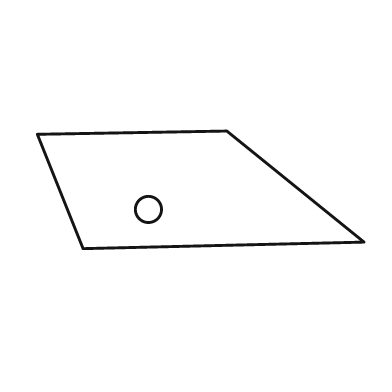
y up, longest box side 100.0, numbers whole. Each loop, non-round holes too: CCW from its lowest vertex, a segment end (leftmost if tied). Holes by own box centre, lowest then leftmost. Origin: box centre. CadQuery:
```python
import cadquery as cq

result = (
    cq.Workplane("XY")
    .moveTo(-36.0, -18.0)
    .lineTo(50.0, -16.0)
    .lineTo(8.0, 18.0)
    .lineTo(-50.0, 17.0)
    .close()
    .moveTo(-16.0, -6.0)
    .circle(4.0)
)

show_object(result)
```